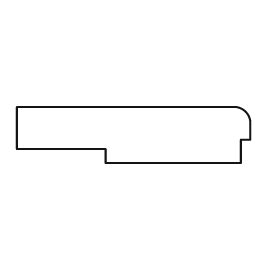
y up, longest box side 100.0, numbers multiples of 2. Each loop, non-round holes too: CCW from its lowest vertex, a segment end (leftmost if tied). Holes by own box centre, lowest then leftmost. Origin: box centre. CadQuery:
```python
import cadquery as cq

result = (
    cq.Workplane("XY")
    .moveTo(-12.0, -12.0)
    .lineTo(46.0, -12.0)
    .lineTo(46.0, -2.0)
    .lineTo(50.0, -2.0)
    .lineTo(50.0, 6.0)
    .threePointArc((48.0, 10.0), (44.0, 12.0))
    .lineTo(-50.0, 12.0)
    .lineTo(-50.0, -6.0)
    .lineTo(-12.0, -6.0)
    .close()
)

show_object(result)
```